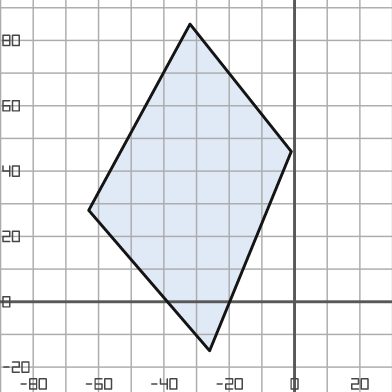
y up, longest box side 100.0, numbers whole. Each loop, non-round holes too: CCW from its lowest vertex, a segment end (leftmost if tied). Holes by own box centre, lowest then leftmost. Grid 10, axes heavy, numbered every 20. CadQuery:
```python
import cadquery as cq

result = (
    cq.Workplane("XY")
    .moveTo(-26.0, -15.0)
    .lineTo(-1.0, 46.0)
    .lineTo(-32.0, 85.0)
    .lineTo(-63.0, 28.0)
    .close()
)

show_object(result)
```